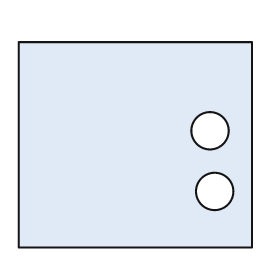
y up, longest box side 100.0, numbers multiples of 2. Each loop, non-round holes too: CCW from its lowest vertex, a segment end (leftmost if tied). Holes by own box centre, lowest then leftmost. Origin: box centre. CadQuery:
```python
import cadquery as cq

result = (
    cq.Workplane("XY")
    .moveTo(-50.0, -44.0)
    .lineTo(50.0, -44.0)
    .lineTo(50.0, 44.0)
    .lineTo(-50.0, 44.0)
    .close()
    .moveTo(34.0, -20.0)
    .circle(8.0)
    .moveTo(32.0, 6.0)
    .circle(8.0)
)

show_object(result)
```